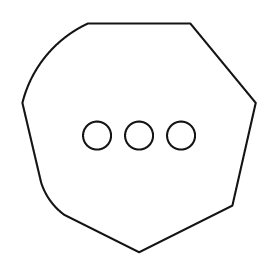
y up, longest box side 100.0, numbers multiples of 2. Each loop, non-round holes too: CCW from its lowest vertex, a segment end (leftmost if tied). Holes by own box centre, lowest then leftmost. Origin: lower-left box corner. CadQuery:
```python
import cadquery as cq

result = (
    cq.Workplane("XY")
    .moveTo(50.0, 0.0)
    .lineTo(90.0, 20.0)
    .lineTo(100.0, 64.0)
    .lineTo(72.0, 98.0)
    .lineTo(28.0, 98.0)
    .threePointArc((10.0, 84.0), (0.0, 64.0))
    .lineTo(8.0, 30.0)
    .threePointArc((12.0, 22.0), (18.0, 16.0))
    .close()
    .moveTo(32.0, 50.0)
    .circle(6.0)
    .moveTo(50.0, 50.0)
    .circle(6.0)
    .moveTo(68.0, 50.0)
    .circle(6.0)
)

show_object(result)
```